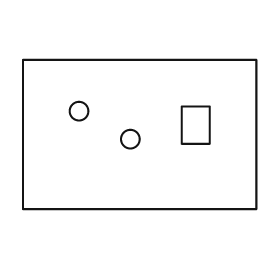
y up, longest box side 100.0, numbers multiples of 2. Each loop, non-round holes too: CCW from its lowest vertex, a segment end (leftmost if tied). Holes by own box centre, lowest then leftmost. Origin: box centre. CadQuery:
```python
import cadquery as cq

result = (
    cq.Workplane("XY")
    .moveTo(-50.0, -32.0)
    .lineTo(50.0, -32.0)
    .lineTo(50.0, 32.0)
    .lineTo(-50.0, 32.0)
    .close()
    .moveTo(-4.0, -2.0)
    .circle(4.0)
    .moveTo(18.0, -4.0)
    .lineTo(30.0, -4.0)
    .lineTo(30.0, 12.0)
    .lineTo(18.0, 12.0)
    .close()
    .moveTo(-26.0, 10.0)
    .circle(4.0)
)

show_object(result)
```